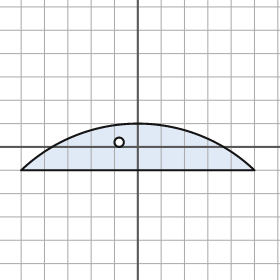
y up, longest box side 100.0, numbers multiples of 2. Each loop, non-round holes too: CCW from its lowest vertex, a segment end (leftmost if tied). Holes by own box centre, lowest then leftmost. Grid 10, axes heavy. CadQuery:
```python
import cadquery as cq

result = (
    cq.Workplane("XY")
    .moveTo(-50.0, -10.0)
    .lineTo(50.0, -10.0)
    .threePointArc((0.0, 10.0), (-50.0, -10.0))
    .close()
    .moveTo(-8.0, 2.0)
    .circle(2.0)
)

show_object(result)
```